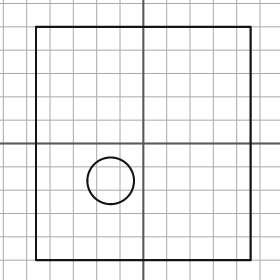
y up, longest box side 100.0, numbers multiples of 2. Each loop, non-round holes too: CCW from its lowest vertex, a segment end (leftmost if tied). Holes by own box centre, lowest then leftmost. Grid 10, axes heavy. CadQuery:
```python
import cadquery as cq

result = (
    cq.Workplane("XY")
    .moveTo(-46.0, -50.0)
    .lineTo(46.0, -50.0)
    .lineTo(46.0, 50.0)
    .lineTo(-46.0, 50.0)
    .close()
    .moveTo(-14.0, -16.0)
    .circle(10.0)
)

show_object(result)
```